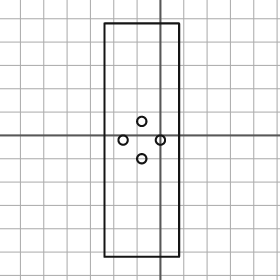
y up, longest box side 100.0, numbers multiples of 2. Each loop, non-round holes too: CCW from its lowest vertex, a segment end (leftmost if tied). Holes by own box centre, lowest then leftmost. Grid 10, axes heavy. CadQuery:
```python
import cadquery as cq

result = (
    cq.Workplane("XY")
    .moveTo(-24.0, -52.0)
    .lineTo(8.0, -52.0)
    .lineTo(8.0, 48.0)
    .lineTo(-24.0, 48.0)
    .close()
    .moveTo(-8.0, -10.0)
    .circle(2.0)
    .moveTo(-16.0, -2.0)
    .circle(2.0)
    .moveTo(0.0, -2.0)
    .circle(2.0)
    .moveTo(-8.0, 6.0)
    .circle(2.0)
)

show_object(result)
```